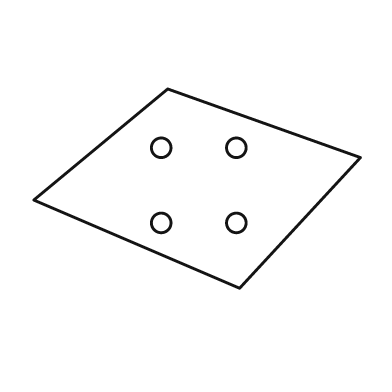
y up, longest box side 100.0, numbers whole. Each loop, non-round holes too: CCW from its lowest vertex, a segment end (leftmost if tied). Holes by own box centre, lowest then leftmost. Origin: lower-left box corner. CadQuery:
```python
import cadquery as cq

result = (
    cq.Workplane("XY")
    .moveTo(63.0, 0.0)
    .lineTo(100.0, 40.0)
    .lineTo(41.0, 61.0)
    .lineTo(0.0, 27.0)
    .close()
    .moveTo(39.0, 20.0)
    .circle(3.0)
    .moveTo(62.0, 20.0)
    .circle(3.0)
    .moveTo(39.0, 43.0)
    .circle(3.0)
    .moveTo(62.0, 43.0)
    .circle(3.0)
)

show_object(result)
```